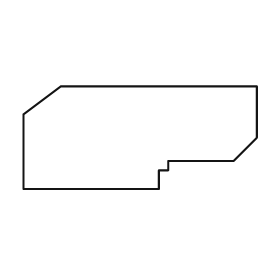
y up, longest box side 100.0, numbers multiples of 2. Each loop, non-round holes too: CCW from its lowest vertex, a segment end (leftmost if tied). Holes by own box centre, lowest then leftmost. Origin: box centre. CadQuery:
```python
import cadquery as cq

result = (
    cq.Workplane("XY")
    .moveTo(-50.0, -22.0)
    .lineTo(8.0, -22.0)
    .lineTo(8.0, -14.0)
    .lineTo(12.0, -14.0)
    .lineTo(12.0, -10.0)
    .lineTo(40.0, -10.0)
    .lineTo(50.0, 0.0)
    .lineTo(50.0, 22.0)
    .lineTo(-34.0, 22.0)
    .lineTo(-50.0, 10.0)
    .close()
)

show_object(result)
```